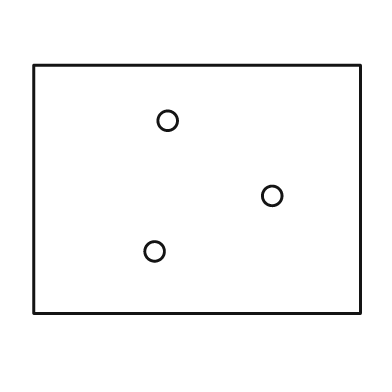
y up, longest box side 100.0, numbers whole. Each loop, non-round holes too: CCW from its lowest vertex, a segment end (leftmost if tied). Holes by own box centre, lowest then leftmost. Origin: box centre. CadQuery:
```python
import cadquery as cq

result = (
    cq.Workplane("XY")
    .moveTo(-50.0, -38.0)
    .lineTo(50.0, -38.0)
    .lineTo(50.0, 38.0)
    .lineTo(-50.0, 38.0)
    .close()
    .moveTo(-13.0, -19.0)
    .circle(3.0)
    .moveTo(23.0, -2.0)
    .circle(3.0)
    .moveTo(-9.0, 21.0)
    .circle(3.0)
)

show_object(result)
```